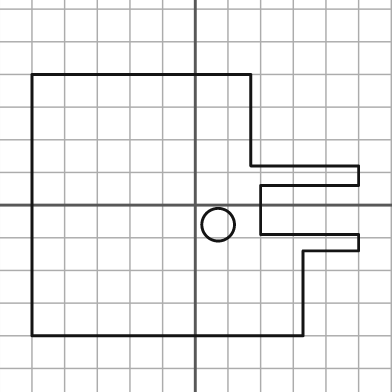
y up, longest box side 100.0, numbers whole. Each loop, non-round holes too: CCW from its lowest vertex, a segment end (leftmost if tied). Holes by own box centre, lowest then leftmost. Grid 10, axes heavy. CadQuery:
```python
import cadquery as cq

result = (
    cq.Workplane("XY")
    .moveTo(-50.0, -40.0)
    .lineTo(33.0, -40.0)
    .lineTo(33.0, -14.0)
    .lineTo(50.0, -14.0)
    .lineTo(50.0, -9.0)
    .lineTo(20.0, -9.0)
    .lineTo(20.0, 6.0)
    .lineTo(50.0, 6.0)
    .lineTo(50.0, 12.0)
    .lineTo(17.0, 12.0)
    .lineTo(17.0, 40.0)
    .lineTo(-50.0, 40.0)
    .close()
    .moveTo(7.0, -6.0)
    .circle(5.0)
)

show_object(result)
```